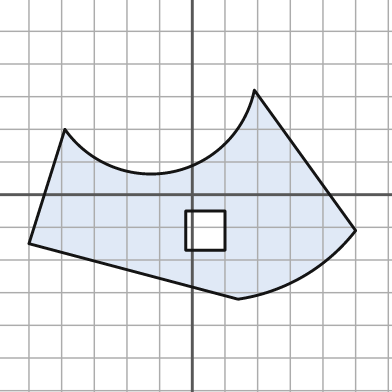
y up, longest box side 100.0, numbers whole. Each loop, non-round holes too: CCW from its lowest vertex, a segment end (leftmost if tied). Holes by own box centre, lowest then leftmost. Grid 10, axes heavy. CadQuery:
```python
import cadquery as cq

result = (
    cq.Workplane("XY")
    .moveTo(14.0, -32.0)
    .threePointArc((34.0, -25.0), (50.0, -11.0))
    .lineTo(19.0, 32.0)
    .threePointArc((-6.0, 7.0), (-39.0, 20.0))
    .lineTo(-50.0, -15.0)
    .close()
    .moveTo(-2.0, -17.0)
    .lineTo(10.0, -17.0)
    .lineTo(10.0, -5.0)
    .lineTo(-2.0, -5.0)
    .close()
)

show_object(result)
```